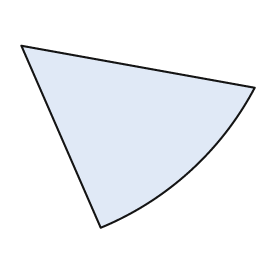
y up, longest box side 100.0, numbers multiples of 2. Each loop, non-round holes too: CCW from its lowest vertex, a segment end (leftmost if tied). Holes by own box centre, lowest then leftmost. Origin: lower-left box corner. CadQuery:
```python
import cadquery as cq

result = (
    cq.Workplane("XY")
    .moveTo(34.0, 0.0)
    .threePointArc((72.0, 24.0), (100.0, 60.0))
    .lineTo(0.0, 78.0)
    .close()
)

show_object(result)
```